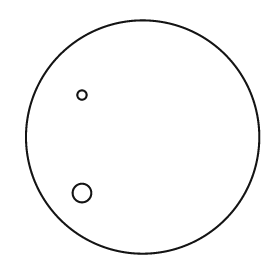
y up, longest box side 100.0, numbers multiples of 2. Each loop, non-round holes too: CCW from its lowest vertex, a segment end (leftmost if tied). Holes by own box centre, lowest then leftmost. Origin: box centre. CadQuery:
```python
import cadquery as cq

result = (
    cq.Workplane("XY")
    .moveTo(0.0, 0.0)
    .circle(50.0)
    .moveTo(-26.0, -24.0)
    .circle(4.0)
    .moveTo(-26.0, 18.0)
    .circle(2.0)
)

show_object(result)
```